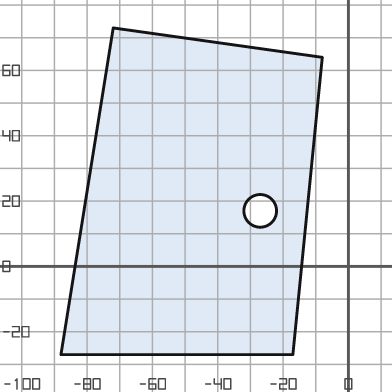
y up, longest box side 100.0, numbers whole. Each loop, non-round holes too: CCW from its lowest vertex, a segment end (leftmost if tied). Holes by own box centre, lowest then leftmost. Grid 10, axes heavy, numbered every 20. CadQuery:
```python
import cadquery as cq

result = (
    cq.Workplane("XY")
    .moveTo(-88.0, -27.0)
    .lineTo(-17.0, -27.0)
    .lineTo(-8.0, 64.0)
    .lineTo(-72.0, 73.0)
    .close()
    .moveTo(-27.0, 17.0)
    .circle(5.0)
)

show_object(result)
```